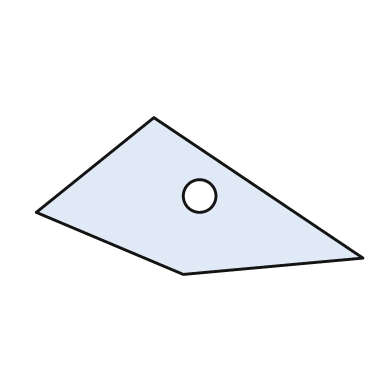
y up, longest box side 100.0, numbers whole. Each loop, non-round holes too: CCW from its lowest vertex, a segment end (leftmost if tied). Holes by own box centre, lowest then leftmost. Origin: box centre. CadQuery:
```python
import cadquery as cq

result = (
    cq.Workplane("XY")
    .moveTo(-5.0, -24.0)
    .lineTo(50.0, -19.0)
    .lineTo(-14.0, 24.0)
    .lineTo(-50.0, -5.0)
    .close()
    .moveTo(0.0, 0.0)
    .circle(5.0)
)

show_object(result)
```